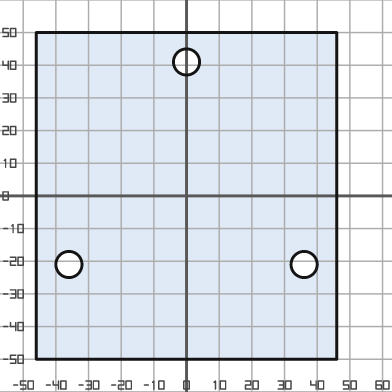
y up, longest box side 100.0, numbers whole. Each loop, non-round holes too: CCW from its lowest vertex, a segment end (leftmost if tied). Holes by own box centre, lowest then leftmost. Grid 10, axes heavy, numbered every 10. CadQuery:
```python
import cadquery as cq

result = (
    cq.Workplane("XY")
    .moveTo(-46.0, -50.0)
    .lineTo(46.0, -50.0)
    .lineTo(46.0, 50.0)
    .lineTo(-46.0, 50.0)
    .close()
    .moveTo(-36.0, -21.0)
    .circle(4.0)
    .moveTo(36.0, -21.0)
    .circle(4.0)
    .moveTo(0.0, 41.0)
    .circle(4.0)
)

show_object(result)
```